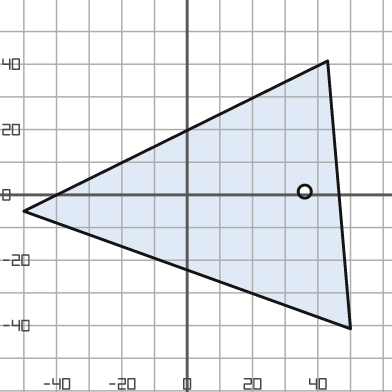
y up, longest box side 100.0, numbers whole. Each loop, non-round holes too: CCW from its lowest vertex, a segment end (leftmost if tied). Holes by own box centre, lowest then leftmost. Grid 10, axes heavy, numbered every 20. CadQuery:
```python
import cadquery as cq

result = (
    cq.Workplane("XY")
    .moveTo(50.0, -41.0)
    .lineTo(43.0, 41.0)
    .lineTo(-50.0, -5.0)
    .close()
    .moveTo(36.0, 1.0)
    .circle(2.0)
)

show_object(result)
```